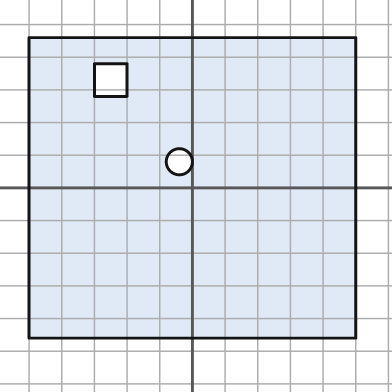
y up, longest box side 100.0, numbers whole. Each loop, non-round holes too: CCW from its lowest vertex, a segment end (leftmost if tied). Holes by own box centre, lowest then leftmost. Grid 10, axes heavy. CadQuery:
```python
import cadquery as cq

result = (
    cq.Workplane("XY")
    .moveTo(-50.0, -46.0)
    .lineTo(50.0, -46.0)
    .lineTo(50.0, 46.0)
    .lineTo(-50.0, 46.0)
    .close()
    .moveTo(-4.0, 8.0)
    .circle(4.0)
    .moveTo(-30.0, 28.0)
    .lineTo(-20.0, 28.0)
    .lineTo(-20.0, 38.0)
    .lineTo(-30.0, 38.0)
    .close()
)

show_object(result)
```